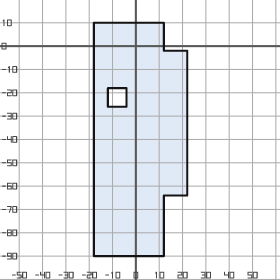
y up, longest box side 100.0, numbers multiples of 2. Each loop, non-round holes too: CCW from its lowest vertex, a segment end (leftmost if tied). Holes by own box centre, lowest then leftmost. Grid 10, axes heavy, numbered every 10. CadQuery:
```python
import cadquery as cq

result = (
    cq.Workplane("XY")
    .moveTo(-18.0, -90.0)
    .lineTo(12.0, -90.0)
    .lineTo(12.0, -64.0)
    .lineTo(22.0, -64.0)
    .lineTo(22.0, -2.0)
    .lineTo(12.0, -2.0)
    .lineTo(12.0, 10.0)
    .lineTo(-18.0, 10.0)
    .close()
    .moveTo(-12.0, -26.0)
    .lineTo(-4.0, -26.0)
    .lineTo(-4.0, -18.0)
    .lineTo(-12.0, -18.0)
    .close()
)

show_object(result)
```